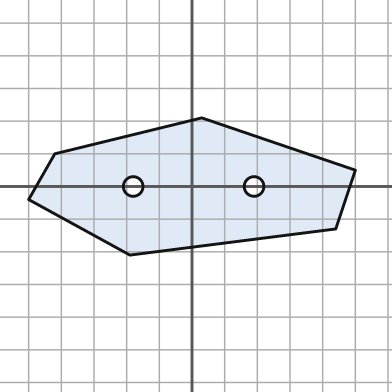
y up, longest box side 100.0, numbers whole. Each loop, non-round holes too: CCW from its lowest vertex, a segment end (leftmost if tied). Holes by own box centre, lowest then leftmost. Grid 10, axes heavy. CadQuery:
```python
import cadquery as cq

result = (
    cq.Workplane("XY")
    .moveTo(-19.0, -21.0)
    .lineTo(44.0, -13.0)
    .lineTo(50.0, 5.0)
    .lineTo(3.0, 21.0)
    .lineTo(-42.0, 10.0)
    .lineTo(-50.0, -4.0)
    .close()
    .moveTo(-18.0, 0.0)
    .circle(3.0)
    .moveTo(19.0, 0.0)
    .circle(3.0)
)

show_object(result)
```